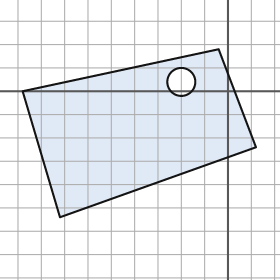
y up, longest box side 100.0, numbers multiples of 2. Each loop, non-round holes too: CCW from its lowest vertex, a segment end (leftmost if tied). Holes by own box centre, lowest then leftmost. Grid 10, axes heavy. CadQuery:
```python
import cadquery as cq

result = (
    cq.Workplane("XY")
    .moveTo(-72.0, -54.0)
    .lineTo(12.0, -24.0)
    .lineTo(-4.0, 18.0)
    .lineTo(-88.0, 0.0)
    .close()
    .moveTo(-20.0, 4.0)
    .circle(6.0)
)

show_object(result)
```